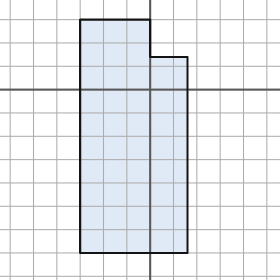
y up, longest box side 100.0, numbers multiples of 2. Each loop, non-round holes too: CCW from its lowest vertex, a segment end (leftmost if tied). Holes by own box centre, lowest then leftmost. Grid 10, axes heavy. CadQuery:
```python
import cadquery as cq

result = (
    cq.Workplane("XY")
    .moveTo(-30.0, -70.0)
    .lineTo(16.0, -70.0)
    .lineTo(16.0, 14.0)
    .lineTo(0.0, 14.0)
    .lineTo(0.0, 30.0)
    .lineTo(-30.0, 30.0)
    .close()
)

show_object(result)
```